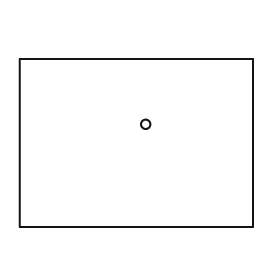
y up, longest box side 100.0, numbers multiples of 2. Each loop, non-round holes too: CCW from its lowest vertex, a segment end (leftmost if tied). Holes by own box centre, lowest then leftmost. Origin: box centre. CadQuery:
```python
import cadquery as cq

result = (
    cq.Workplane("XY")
    .moveTo(-50.0, -36.0)
    .lineTo(50.0, -36.0)
    .lineTo(50.0, 36.0)
    .lineTo(-50.0, 36.0)
    .close()
    .moveTo(4.0, 8.0)
    .circle(2.0)
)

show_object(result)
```